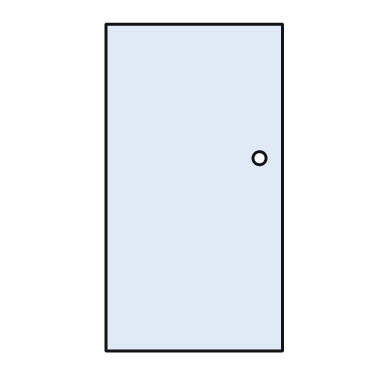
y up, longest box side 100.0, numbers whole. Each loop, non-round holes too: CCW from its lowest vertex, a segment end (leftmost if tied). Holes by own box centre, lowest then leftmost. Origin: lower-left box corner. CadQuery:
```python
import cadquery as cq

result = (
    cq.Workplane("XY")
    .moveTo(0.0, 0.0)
    .lineTo(54.0, 0.0)
    .lineTo(54.0, 100.0)
    .lineTo(0.0, 100.0)
    .close()
    .moveTo(47.0, 59.0)
    .circle(2.0)
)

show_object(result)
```